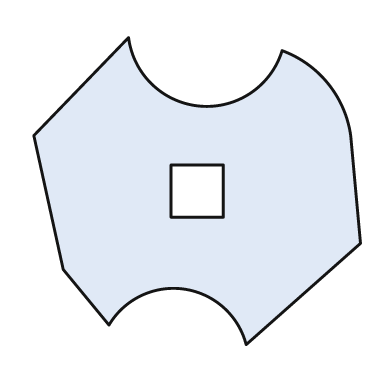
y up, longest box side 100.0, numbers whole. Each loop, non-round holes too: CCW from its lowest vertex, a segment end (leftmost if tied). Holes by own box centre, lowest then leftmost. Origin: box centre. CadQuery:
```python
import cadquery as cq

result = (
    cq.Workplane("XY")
    .moveTo(15.0, -47.0)
    .lineTo(50.0, -16.0)
    .lineTo(47.0, 17.0)
    .threePointArc((40.0, 33.0), (26.0, 43.0))
    .threePointArc((1.0, 26.0), (-21.0, 47.0))
    .lineTo(-50.0, 17.0)
    .lineTo(-41.0, -24.0)
    .lineTo(-27.0, -41.0)
    .threePointArc((-4.0, -30.0), (15.0, -47.0))
    .close()
    .moveTo(-8.0, -8.0)
    .lineTo(8.0, -8.0)
    .lineTo(8.0, 8.0)
    .lineTo(-8.0, 8.0)
    .close()
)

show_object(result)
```